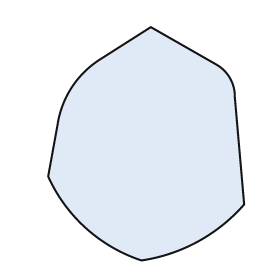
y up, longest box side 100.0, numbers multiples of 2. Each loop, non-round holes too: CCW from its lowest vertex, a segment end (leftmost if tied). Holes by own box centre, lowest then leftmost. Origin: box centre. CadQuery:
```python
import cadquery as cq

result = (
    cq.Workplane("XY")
    .moveTo(-2.0, -50.0)
    .threePointArc((22.0, -42.0), (42.0, -26.0))
    .lineTo(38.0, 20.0)
    .threePointArc((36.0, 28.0), (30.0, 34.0))
    .lineTo(2.0, 50.0)
    .lineTo(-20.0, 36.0)
    .threePointArc((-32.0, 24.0), (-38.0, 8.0))
    .lineTo(-42.0, -14.0)
    .threePointArc((-26.0, -36.0), (-2.0, -50.0))
    .close()
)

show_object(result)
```